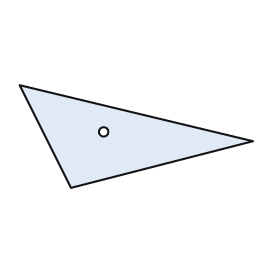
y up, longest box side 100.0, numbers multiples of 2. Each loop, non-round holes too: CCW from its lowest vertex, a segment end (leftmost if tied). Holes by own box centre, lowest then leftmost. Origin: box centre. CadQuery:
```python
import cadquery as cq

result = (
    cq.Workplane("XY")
    .moveTo(-28.0, -22.0)
    .lineTo(50.0, -2.0)
    .lineTo(-50.0, 22.0)
    .close()
    .moveTo(-14.0, 2.0)
    .circle(2.0)
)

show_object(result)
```